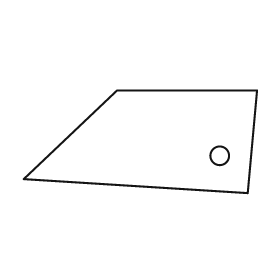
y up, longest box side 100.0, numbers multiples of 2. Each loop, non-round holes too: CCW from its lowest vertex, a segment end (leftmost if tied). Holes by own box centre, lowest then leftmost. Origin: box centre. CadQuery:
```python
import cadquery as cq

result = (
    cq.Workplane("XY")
    .moveTo(46.0, -22.0)
    .lineTo(50.0, 22.0)
    .lineTo(-10.0, 22.0)
    .lineTo(-50.0, -16.0)
    .close()
    .moveTo(34.0, -6.0)
    .circle(4.0)
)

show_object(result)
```